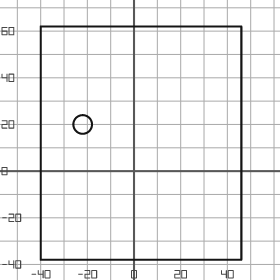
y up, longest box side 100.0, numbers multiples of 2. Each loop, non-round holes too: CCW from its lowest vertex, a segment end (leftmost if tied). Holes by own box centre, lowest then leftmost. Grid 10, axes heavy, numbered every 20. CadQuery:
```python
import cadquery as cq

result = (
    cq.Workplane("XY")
    .moveTo(-40.0, -38.0)
    .lineTo(46.0, -38.0)
    .lineTo(46.0, 62.0)
    .lineTo(-40.0, 62.0)
    .close()
    .moveTo(-22.0, 20.0)
    .circle(4.0)
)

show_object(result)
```